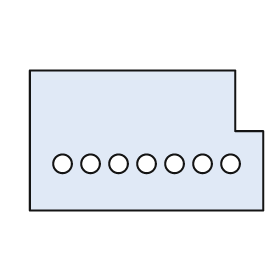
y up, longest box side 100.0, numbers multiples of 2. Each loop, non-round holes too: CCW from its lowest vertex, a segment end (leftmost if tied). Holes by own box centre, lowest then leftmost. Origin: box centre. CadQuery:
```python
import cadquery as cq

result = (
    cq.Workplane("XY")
    .moveTo(-50.0, -30.0)
    .lineTo(50.0, -30.0)
    .lineTo(50.0, 4.0)
    .lineTo(38.0, 4.0)
    .lineTo(38.0, 30.0)
    .lineTo(-50.0, 30.0)
    .close()
    .moveTo(-36.0, -10.0)
    .circle(4.0)
    .moveTo(-24.0, -10.0)
    .circle(4.0)
    .moveTo(-12.0, -10.0)
    .circle(4.0)
    .moveTo(0.0, -10.0)
    .circle(4.0)
    .moveTo(12.0, -10.0)
    .circle(4.0)
    .moveTo(24.0, -10.0)
    .circle(4.0)
    .moveTo(36.0, -10.0)
    .circle(4.0)
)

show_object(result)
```